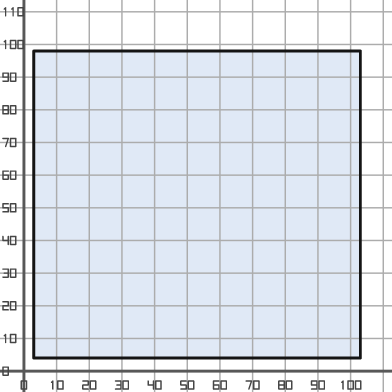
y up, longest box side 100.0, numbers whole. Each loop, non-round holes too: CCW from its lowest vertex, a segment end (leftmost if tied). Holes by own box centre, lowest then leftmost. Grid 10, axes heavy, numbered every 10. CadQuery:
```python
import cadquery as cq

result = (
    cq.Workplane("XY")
    .moveTo(3.0, 4.0)
    .lineTo(103.0, 4.0)
    .lineTo(103.0, 98.0)
    .lineTo(3.0, 98.0)
    .close()
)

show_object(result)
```